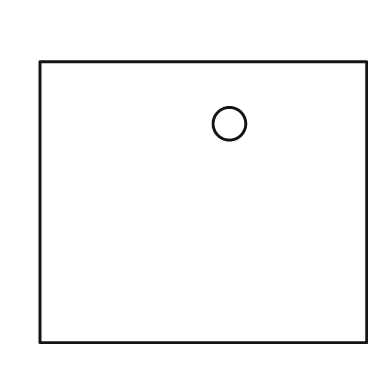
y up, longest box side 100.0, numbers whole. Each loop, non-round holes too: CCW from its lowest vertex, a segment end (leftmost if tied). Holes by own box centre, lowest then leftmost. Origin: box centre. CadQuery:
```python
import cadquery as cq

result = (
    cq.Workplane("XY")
    .moveTo(-50.0, -43.0)
    .lineTo(50.0, -43.0)
    .lineTo(50.0, 43.0)
    .lineTo(-50.0, 43.0)
    .close()
    .moveTo(8.0, 24.0)
    .circle(5.0)
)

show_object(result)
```